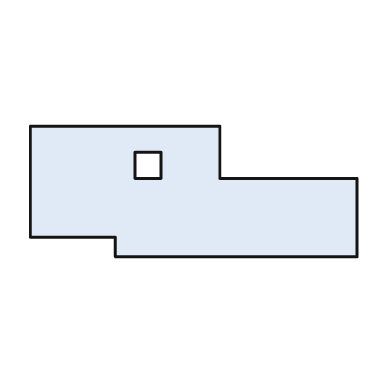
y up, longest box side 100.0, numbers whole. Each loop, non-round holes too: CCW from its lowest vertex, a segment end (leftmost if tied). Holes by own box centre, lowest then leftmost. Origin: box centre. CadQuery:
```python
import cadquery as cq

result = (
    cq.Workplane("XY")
    .moveTo(-24.0, -20.0)
    .lineTo(50.0, -20.0)
    .lineTo(50.0, 4.0)
    .lineTo(8.0, 4.0)
    .lineTo(8.0, 20.0)
    .lineTo(-50.0, 20.0)
    .lineTo(-50.0, -14.0)
    .lineTo(-24.0, -14.0)
    .close()
    .moveTo(-18.0, 4.0)
    .lineTo(-10.0, 4.0)
    .lineTo(-10.0, 12.0)
    .lineTo(-18.0, 12.0)
    .close()
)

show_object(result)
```